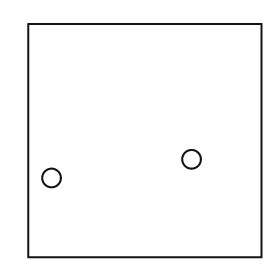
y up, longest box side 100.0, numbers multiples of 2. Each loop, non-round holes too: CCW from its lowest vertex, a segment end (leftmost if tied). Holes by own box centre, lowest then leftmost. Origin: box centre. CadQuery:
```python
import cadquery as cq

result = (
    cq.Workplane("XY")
    .moveTo(-50.0, -50.0)
    .lineTo(50.0, -50.0)
    .lineTo(50.0, 50.0)
    .lineTo(-50.0, 50.0)
    .close()
    .moveTo(-40.0, -16.0)
    .circle(4.0)
    .moveTo(20.0, -8.0)
    .circle(4.0)
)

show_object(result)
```